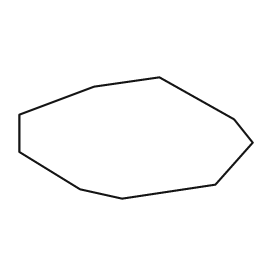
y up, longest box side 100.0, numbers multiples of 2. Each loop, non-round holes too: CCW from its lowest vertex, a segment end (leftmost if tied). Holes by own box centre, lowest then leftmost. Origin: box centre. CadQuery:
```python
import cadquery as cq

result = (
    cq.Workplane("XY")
    .moveTo(-6.0, -26.0)
    .lineTo(34.0, -20.0)
    .lineTo(50.0, -2.0)
    .lineTo(42.0, 8.0)
    .lineTo(10.0, 26.0)
    .lineTo(-18.0, 22.0)
    .lineTo(-50.0, 10.0)
    .lineTo(-50.0, -6.0)
    .lineTo(-24.0, -22.0)
    .close()
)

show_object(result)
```